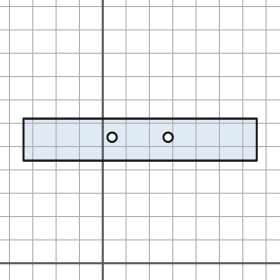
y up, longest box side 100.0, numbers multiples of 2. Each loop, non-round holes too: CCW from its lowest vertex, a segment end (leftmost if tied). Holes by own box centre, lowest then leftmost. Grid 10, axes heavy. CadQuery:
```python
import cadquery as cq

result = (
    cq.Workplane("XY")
    .moveTo(-34.0, 44.0)
    .lineTo(66.0, 44.0)
    .lineTo(66.0, 62.0)
    .lineTo(-34.0, 62.0)
    .close()
    .moveTo(4.0, 54.0)
    .circle(2.0)
    .moveTo(28.0, 54.0)
    .circle(2.0)
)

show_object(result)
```